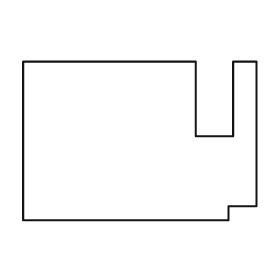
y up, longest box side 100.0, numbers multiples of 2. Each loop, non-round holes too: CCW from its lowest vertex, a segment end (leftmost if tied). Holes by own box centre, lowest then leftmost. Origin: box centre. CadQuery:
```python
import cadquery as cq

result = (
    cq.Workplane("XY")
    .moveTo(-50.0, -34.0)
    .lineTo(38.0, -34.0)
    .lineTo(38.0, -28.0)
    .lineTo(50.0, -28.0)
    .lineTo(50.0, 34.0)
    .lineTo(40.0, 34.0)
    .lineTo(40.0, 2.0)
    .lineTo(24.0, 2.0)
    .lineTo(24.0, 34.0)
    .lineTo(-50.0, 34.0)
    .close()
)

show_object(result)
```